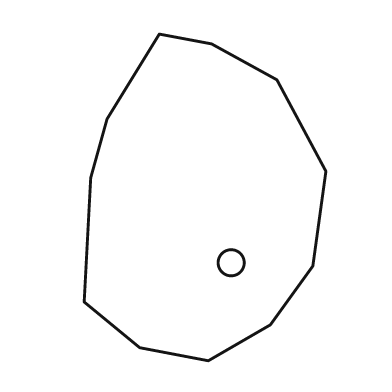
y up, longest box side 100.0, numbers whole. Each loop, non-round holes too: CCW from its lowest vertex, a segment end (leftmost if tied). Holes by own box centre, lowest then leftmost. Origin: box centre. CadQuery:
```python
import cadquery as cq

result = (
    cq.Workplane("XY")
    .moveTo(1.0, -50.0)
    .lineTo(20.0, -39.0)
    .lineTo(33.0, -21.0)
    .lineTo(37.0, 8.0)
    .lineTo(22.0, 36.0)
    .lineTo(2.0, 47.0)
    .lineTo(-14.0, 50.0)
    .lineTo(-30.0, 24.0)
    .lineTo(-35.0, 6.0)
    .lineTo(-37.0, -32.0)
    .lineTo(-20.0, -46.0)
    .close()
    .moveTo(8.0, -20.0)
    .circle(4.0)
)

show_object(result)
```